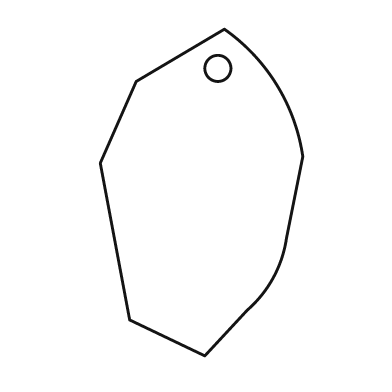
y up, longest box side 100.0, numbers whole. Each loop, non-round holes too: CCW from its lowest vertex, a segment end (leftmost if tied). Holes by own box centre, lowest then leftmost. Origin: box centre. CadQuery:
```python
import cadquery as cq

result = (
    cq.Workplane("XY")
    .moveTo(1.0, -50.0)
    .lineTo(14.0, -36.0)
    .threePointArc((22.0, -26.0), (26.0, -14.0))
    .lineTo(31.0, 11.0)
    .threePointArc((23.0, 33.0), (7.0, 50.0))
    .lineTo(-20.0, 34.0)
    .lineTo(-31.0, 9.0)
    .lineTo(-22.0, -39.0)
    .close()
    .moveTo(5.0, 38.0)
    .circle(4.0)
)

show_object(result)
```